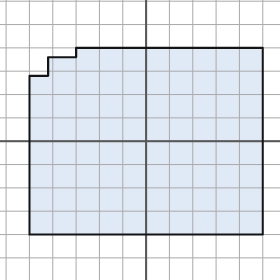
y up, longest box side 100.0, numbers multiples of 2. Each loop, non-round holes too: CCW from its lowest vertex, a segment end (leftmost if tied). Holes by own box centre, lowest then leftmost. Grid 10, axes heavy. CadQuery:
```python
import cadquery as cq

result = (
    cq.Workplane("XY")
    .moveTo(-50.0, -40.0)
    .lineTo(50.0, -40.0)
    .lineTo(50.0, 40.0)
    .lineTo(-30.0, 40.0)
    .lineTo(-30.0, 36.0)
    .lineTo(-42.0, 36.0)
    .lineTo(-42.0, 28.0)
    .lineTo(-50.0, 28.0)
    .close()
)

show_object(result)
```